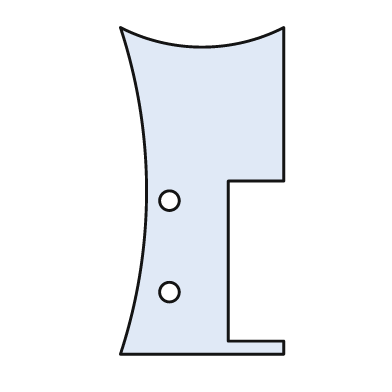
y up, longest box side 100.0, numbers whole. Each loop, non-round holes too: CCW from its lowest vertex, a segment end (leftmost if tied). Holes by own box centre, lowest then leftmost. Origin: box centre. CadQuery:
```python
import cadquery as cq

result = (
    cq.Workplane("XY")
    .moveTo(-25.0, -50.0)
    .lineTo(25.0, -50.0)
    .lineTo(25.0, -46.0)
    .lineTo(8.0, -46.0)
    .lineTo(8.0, 3.0)
    .lineTo(25.0, 3.0)
    .lineTo(25.0, 50.0)
    .threePointArc((0.0, 44.0), (-25.0, 50.0))
    .threePointArc((-17.0, 0.0), (-25.0, -50.0))
    .close()
    .moveTo(-10.0, -31.0)
    .circle(3.0)
    .moveTo(-10.0, -3.0)
    .circle(3.0)
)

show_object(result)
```